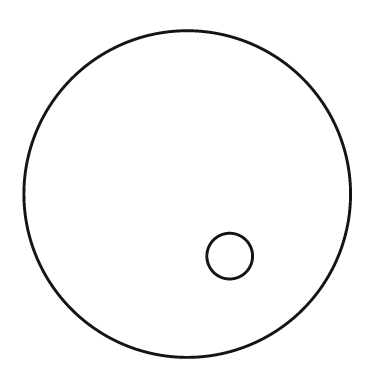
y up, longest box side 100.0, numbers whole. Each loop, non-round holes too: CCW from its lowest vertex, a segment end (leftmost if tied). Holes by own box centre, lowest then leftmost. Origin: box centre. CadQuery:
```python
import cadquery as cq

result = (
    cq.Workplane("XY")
    .moveTo(0.0, 0.0)
    .circle(50.0)
    .moveTo(13.0, -19.0)
    .circle(7.0)
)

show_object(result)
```